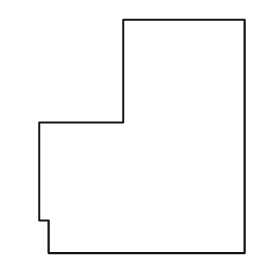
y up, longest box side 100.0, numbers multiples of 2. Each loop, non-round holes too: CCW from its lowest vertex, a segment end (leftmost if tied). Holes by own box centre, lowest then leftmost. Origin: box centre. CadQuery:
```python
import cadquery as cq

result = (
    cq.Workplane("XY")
    .moveTo(-40.0, -50.0)
    .lineTo(44.0, -50.0)
    .lineTo(44.0, 50.0)
    .lineTo(-8.0, 50.0)
    .lineTo(-8.0, 6.0)
    .lineTo(-44.0, 6.0)
    .lineTo(-44.0, -36.0)
    .lineTo(-40.0, -36.0)
    .close()
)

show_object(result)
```